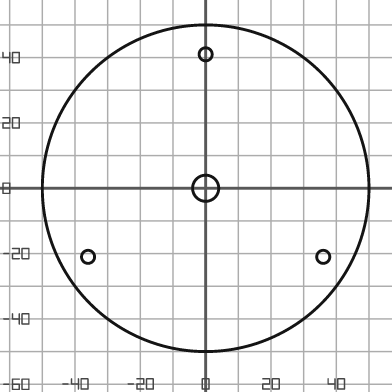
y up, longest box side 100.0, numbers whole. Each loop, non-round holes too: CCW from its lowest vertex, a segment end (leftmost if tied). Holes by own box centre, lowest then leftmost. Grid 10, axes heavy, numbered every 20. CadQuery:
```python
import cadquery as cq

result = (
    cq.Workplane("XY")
    .moveTo(0.0, 0.0)
    .circle(50.0)
    .moveTo(-36.0, -21.0)
    .circle(2.0)
    .moveTo(36.0, -21.0)
    .circle(2.0)
    .moveTo(0.0, 0.0)
    .circle(4.0)
    .moveTo(0.0, 41.0)
    .circle(2.0)
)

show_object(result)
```